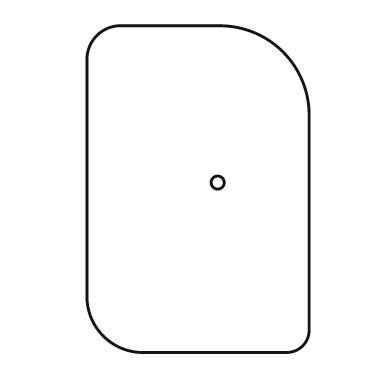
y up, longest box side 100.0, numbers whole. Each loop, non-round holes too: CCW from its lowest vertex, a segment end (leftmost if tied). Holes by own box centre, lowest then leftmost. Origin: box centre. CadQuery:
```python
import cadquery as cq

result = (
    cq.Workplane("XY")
    .moveTo(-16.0, -50.0)
    .lineTo(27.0, -50.0)
    .threePointArc((32.0, -48.0), (34.0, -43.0))
    .lineTo(34.0, 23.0)
    .threePointArc((26.0, 42.0), (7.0, 50.0))
    .lineTo(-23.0, 50.0)
    .threePointArc((-31.0, 47.0), (-34.0, 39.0))
    .lineTo(-34.0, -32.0)
    .threePointArc((-29.0, -45.0), (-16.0, -50.0))
    .close()
    .moveTo(6.0, 2.0)
    .circle(2.0)
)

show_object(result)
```